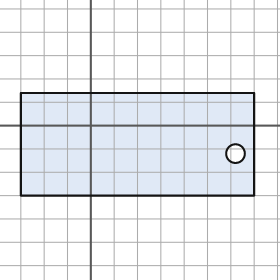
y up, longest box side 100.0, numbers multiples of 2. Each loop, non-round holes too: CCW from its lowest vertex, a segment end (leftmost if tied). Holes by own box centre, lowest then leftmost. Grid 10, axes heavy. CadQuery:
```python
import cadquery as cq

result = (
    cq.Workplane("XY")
    .moveTo(-30.0, -30.0)
    .lineTo(70.0, -30.0)
    .lineTo(70.0, 14.0)
    .lineTo(-30.0, 14.0)
    .close()
    .moveTo(62.0, -12.0)
    .circle(4.0)
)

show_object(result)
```